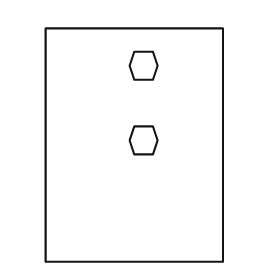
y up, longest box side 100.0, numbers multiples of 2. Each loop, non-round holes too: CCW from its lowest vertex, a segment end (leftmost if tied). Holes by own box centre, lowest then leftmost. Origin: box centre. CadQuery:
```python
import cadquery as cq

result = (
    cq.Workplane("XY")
    .moveTo(-38.0, -50.0)
    .lineTo(38.0, -50.0)
    .lineTo(38.0, 50.0)
    .lineTo(-38.0, 50.0)
    .close()
    .moveTo(0.0, -4.0)
    .lineTo(8.0, -4.0)
    .lineTo(10.0, 2.0)
    .lineTo(8.0, 8.0)
    .lineTo(0.0, 8.0)
    .lineTo(-2.0, 2.0)
    .close()
    .moveTo(0.0, 28.0)
    .lineTo(8.0, 28.0)
    .lineTo(10.0, 34.0)
    .lineTo(8.0, 40.0)
    .lineTo(0.0, 40.0)
    .lineTo(-2.0, 34.0)
    .close()
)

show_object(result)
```